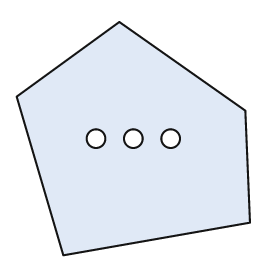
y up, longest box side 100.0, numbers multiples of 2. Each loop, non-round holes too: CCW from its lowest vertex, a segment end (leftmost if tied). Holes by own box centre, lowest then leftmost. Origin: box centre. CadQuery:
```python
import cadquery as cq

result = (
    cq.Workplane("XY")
    .moveTo(-30.0, -50.0)
    .lineTo(50.0, -36.0)
    .lineTo(48.0, 12.0)
    .lineTo(-6.0, 50.0)
    .lineTo(-50.0, 18.0)
    .close()
    .moveTo(-16.0, 0.0)
    .circle(4.0)
    .moveTo(0.0, 0.0)
    .circle(4.0)
    .moveTo(16.0, 0.0)
    .circle(4.0)
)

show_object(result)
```